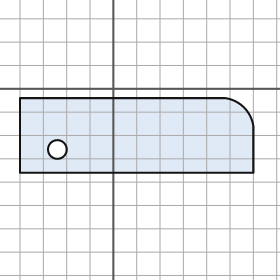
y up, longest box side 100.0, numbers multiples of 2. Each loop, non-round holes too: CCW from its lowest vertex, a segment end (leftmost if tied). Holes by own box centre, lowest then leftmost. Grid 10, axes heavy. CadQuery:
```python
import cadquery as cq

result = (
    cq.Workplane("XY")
    .moveTo(-40.0, -36.0)
    .lineTo(60.0, -36.0)
    .lineTo(60.0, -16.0)
    .threePointArc((56.0, -8.0), (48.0, -4.0))
    .lineTo(-40.0, -4.0)
    .close()
    .moveTo(-24.0, -26.0)
    .circle(4.0)
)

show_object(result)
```